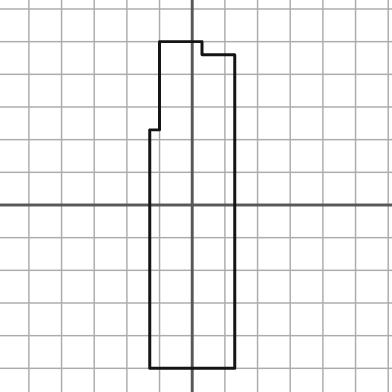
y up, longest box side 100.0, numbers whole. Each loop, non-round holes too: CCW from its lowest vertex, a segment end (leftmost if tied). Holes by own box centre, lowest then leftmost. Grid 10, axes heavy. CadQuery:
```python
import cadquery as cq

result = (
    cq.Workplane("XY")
    .moveTo(-13.0, -50.0)
    .lineTo(13.0, -50.0)
    .lineTo(13.0, 46.0)
    .lineTo(3.0, 46.0)
    .lineTo(3.0, 50.0)
    .lineTo(-10.0, 50.0)
    .lineTo(-10.0, 23.0)
    .lineTo(-13.0, 23.0)
    .close()
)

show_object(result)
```